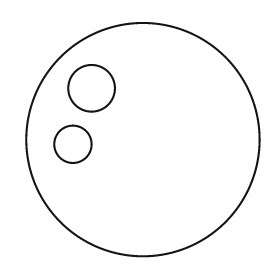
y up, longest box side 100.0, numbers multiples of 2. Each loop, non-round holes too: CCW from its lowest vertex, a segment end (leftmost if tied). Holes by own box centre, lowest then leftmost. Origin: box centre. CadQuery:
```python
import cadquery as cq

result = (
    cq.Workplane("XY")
    .moveTo(0.0, 0.0)
    .circle(50.0)
    .moveTo(-30.0, -2.0)
    .circle(8.0)
    .moveTo(-22.0, 22.0)
    .circle(10.0)
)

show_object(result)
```